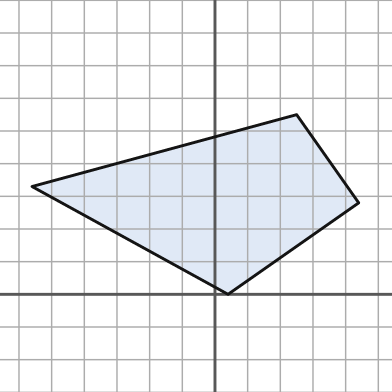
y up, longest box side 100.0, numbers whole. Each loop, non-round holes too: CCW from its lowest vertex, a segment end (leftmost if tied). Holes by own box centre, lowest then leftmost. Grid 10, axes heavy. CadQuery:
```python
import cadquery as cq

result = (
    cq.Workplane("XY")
    .moveTo(4.0, 0.0)
    .lineTo(44.0, 28.0)
    .lineTo(25.0, 55.0)
    .lineTo(-56.0, 33.0)
    .close()
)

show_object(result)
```